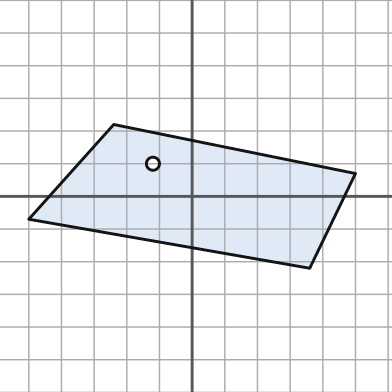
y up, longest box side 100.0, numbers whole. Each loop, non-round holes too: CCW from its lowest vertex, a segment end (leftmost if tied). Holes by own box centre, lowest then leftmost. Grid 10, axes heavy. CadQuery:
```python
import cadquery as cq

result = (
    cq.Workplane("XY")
    .moveTo(36.0, -22.0)
    .lineTo(50.0, 7.0)
    .lineTo(-24.0, 22.0)
    .lineTo(-50.0, -7.0)
    .close()
    .moveTo(-12.0, 10.0)
    .circle(2.0)
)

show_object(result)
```